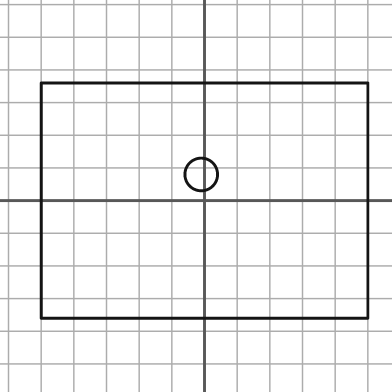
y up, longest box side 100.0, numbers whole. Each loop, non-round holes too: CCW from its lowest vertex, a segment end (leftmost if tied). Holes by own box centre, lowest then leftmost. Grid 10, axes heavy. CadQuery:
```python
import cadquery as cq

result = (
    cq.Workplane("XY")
    .moveTo(-50.0, -36.0)
    .lineTo(50.0, -36.0)
    .lineTo(50.0, 36.0)
    .lineTo(-50.0, 36.0)
    .close()
    .moveTo(-1.0, 8.0)
    .circle(5.0)
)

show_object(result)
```